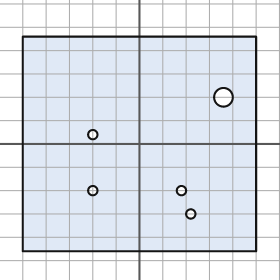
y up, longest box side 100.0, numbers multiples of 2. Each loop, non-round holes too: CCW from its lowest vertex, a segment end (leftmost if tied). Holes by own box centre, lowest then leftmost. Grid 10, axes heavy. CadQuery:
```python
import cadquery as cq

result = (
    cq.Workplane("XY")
    .moveTo(-50.0, -46.0)
    .lineTo(50.0, -46.0)
    .lineTo(50.0, 46.0)
    .lineTo(-50.0, 46.0)
    .close()
    .moveTo(22.0, -30.0)
    .circle(2.0)
    .moveTo(-20.0, -20.0)
    .circle(2.0)
    .moveTo(18.0, -20.0)
    .circle(2.0)
    .moveTo(-20.0, 4.0)
    .circle(2.0)
    .moveTo(36.0, 20.0)
    .circle(4.0)
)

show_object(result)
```